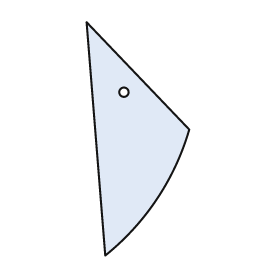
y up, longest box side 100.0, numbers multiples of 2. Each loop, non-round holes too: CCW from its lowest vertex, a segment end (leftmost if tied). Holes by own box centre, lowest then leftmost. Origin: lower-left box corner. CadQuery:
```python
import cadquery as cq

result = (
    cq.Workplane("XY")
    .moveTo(8.0, 0.0)
    .threePointArc((30.0, 24.0), (44.0, 54.0))
    .lineTo(0.0, 100.0)
    .close()
    .moveTo(16.0, 70.0)
    .circle(2.0)
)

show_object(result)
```